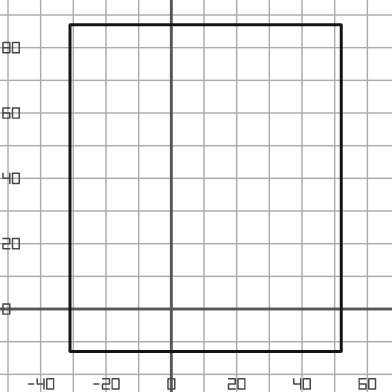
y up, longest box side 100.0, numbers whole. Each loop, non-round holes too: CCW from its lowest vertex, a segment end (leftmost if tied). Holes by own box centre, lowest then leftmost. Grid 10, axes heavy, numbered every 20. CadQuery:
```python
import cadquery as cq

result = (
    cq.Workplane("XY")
    .moveTo(-31.0, -13.0)
    .lineTo(52.0, -13.0)
    .lineTo(52.0, 87.0)
    .lineTo(-31.0, 87.0)
    .close()
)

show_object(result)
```